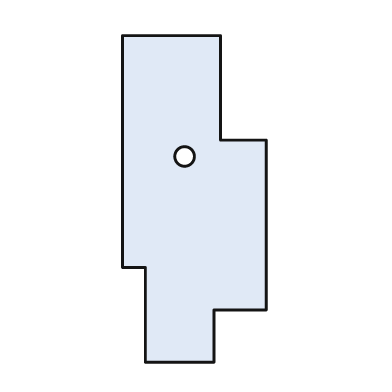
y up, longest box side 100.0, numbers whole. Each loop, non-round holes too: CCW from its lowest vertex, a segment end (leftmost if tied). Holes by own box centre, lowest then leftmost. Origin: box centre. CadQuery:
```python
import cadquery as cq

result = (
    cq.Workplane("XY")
    .moveTo(-15.0, -50.0)
    .lineTo(6.0, -50.0)
    .lineTo(6.0, -34.0)
    .lineTo(22.0, -34.0)
    .lineTo(22.0, 18.0)
    .lineTo(8.0, 18.0)
    .lineTo(8.0, 50.0)
    .lineTo(-22.0, 50.0)
    .lineTo(-22.0, -21.0)
    .lineTo(-15.0, -21.0)
    .close()
    .moveTo(-3.0, 13.0)
    .circle(3.0)
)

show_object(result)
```